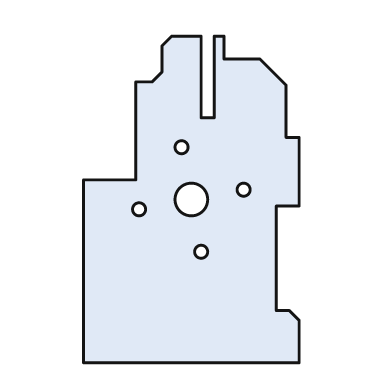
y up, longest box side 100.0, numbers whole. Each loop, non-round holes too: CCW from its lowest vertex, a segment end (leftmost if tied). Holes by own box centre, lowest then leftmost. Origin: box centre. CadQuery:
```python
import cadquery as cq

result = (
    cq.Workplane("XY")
    .moveTo(-33.0, -50.0)
    .lineTo(33.0, -50.0)
    .lineTo(33.0, -37.0)
    .lineTo(30.0, -34.0)
    .lineTo(26.0, -34.0)
    .lineTo(26.0, -2.0)
    .lineTo(33.0, -2.0)
    .lineTo(33.0, 19.0)
    .lineTo(29.0, 19.0)
    .lineTo(29.0, 35.0)
    .lineTo(21.0, 43.0)
    .lineTo(10.0, 43.0)
    .lineTo(10.0, 50.0)
    .lineTo(7.0, 50.0)
    .lineTo(7.0, 25.0)
    .lineTo(3.0, 25.0)
    .lineTo(3.0, 50.0)
    .lineTo(-6.0, 50.0)
    .lineTo(-9.0, 47.0)
    .lineTo(-9.0, 39.0)
    .lineTo(-12.0, 36.0)
    .lineTo(-17.0, 36.0)
    .lineTo(-17.0, 6.0)
    .lineTo(-33.0, 6.0)
    .close()
    .moveTo(3.0, -16.0)
    .circle(2.0)
    .moveTo(-16.0, -3.0)
    .circle(2.0)
    .moveTo(0.0, 0.0)
    .circle(5.0)
    .moveTo(16.0, 3.0)
    .circle(2.0)
    .moveTo(-3.0, 16.0)
    .circle(2.0)
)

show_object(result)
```